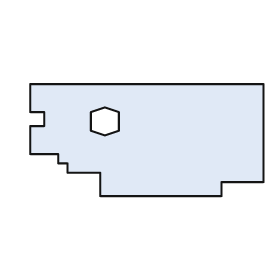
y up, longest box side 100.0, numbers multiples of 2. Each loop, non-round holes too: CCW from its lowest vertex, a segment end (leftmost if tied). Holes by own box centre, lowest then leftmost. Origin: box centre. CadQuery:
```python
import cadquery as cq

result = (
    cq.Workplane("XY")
    .moveTo(-20.0, -24.0)
    .lineTo(32.0, -24.0)
    .lineTo(32.0, -18.0)
    .lineTo(50.0, -18.0)
    .lineTo(50.0, 24.0)
    .lineTo(-50.0, 24.0)
    .lineTo(-50.0, 12.0)
    .lineTo(-44.0, 12.0)
    .lineTo(-44.0, 6.0)
    .lineTo(-50.0, 6.0)
    .lineTo(-50.0, -6.0)
    .lineTo(-38.0, -6.0)
    .lineTo(-38.0, -10.0)
    .lineTo(-34.0, -10.0)
    .lineTo(-34.0, -14.0)
    .lineTo(-20.0, -14.0)
    .close()
    .moveTo(-18.0, 2.0)
    .lineTo(-12.0, 4.0)
    .lineTo(-12.0, 12.0)
    .lineTo(-18.0, 14.0)
    .lineTo(-24.0, 12.0)
    .lineTo(-24.0, 4.0)
    .close()
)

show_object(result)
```